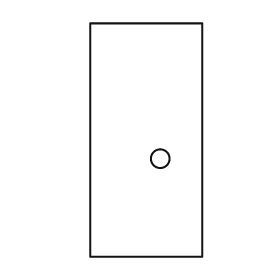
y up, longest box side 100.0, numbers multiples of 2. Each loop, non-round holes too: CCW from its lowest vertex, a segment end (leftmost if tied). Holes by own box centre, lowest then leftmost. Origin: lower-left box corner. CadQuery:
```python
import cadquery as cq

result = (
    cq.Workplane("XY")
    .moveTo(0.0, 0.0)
    .lineTo(48.0, 0.0)
    .lineTo(48.0, 100.0)
    .lineTo(0.0, 100.0)
    .close()
    .moveTo(30.0, 42.0)
    .circle(4.0)
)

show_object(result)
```